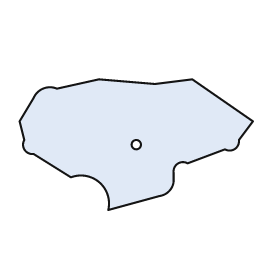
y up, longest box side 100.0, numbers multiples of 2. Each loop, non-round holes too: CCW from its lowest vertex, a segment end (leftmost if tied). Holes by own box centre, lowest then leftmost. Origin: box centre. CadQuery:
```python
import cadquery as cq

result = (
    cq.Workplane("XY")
    .moveTo(-12.0, -28.0)
    .lineTo(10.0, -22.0)
    .threePointArc((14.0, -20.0), (16.0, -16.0))
    .lineTo(16.0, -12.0)
    .threePointArc((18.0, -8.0), (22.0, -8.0))
    .lineTo(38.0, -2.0)
    .threePointArc((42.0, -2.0), (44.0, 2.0))
    .lineTo(50.0, 10.0)
    .lineTo(24.0, 28.0)
    .lineTo(8.0, 26.0)
    .lineTo(-16.0, 28.0)
    .lineTo(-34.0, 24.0)
    .threePointArc((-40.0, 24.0), (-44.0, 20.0))
    .lineTo(-50.0, 10.0)
    .lineTo(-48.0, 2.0)
    .threePointArc((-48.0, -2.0), (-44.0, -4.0))
    .lineTo(-28.0, -14.0)
    .threePointArc((-16.0, -16.0), (-12.0, -28.0))
    .close()
    .moveTo(0.0, 0.0)
    .circle(2.0)
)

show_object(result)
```